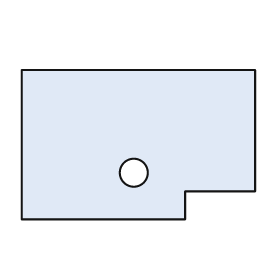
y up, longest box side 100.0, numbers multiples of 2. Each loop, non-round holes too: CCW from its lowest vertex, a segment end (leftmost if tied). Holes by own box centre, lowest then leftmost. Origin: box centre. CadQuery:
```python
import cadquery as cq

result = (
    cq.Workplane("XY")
    .moveTo(-50.0, -32.0)
    .lineTo(20.0, -32.0)
    .lineTo(20.0, -20.0)
    .lineTo(50.0, -20.0)
    .lineTo(50.0, 32.0)
    .lineTo(-50.0, 32.0)
    .close()
    .moveTo(-2.0, -12.0)
    .circle(6.0)
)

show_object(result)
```